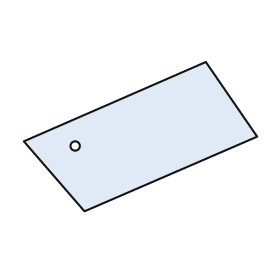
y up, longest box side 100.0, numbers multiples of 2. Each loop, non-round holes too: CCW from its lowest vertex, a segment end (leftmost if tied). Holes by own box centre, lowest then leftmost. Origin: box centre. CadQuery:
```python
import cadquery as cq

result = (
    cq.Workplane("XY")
    .moveTo(-24.0, -32.0)
    .lineTo(50.0, 0.0)
    .lineTo(28.0, 32.0)
    .lineTo(-50.0, -2.0)
    .close()
    .moveTo(-28.0, -4.0)
    .circle(2.0)
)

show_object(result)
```